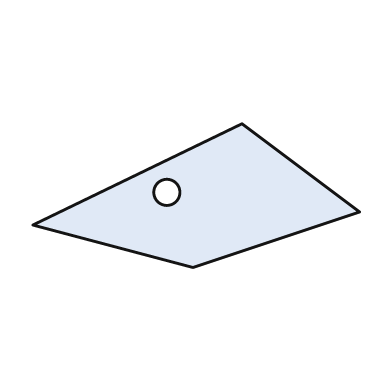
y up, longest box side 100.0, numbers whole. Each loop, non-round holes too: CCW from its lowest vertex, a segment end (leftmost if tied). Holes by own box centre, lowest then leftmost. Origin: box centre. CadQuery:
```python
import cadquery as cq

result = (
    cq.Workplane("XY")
    .moveTo(-1.0, -22.0)
    .lineTo(50.0, -5.0)
    .lineTo(14.0, 22.0)
    .lineTo(-50.0, -9.0)
    .close()
    .moveTo(-9.0, 1.0)
    .circle(4.0)
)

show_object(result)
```